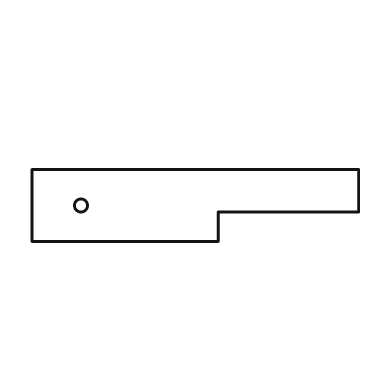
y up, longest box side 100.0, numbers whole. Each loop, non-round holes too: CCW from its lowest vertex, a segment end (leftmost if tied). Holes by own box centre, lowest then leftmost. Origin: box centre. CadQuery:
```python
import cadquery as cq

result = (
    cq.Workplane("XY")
    .moveTo(-50.0, -11.0)
    .lineTo(7.0, -11.0)
    .lineTo(7.0, -2.0)
    .lineTo(50.0, -2.0)
    .lineTo(50.0, 11.0)
    .lineTo(-50.0, 11.0)
    .close()
    .moveTo(-35.0, 0.0)
    .circle(2.0)
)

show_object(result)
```